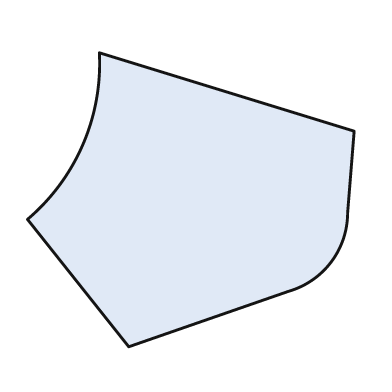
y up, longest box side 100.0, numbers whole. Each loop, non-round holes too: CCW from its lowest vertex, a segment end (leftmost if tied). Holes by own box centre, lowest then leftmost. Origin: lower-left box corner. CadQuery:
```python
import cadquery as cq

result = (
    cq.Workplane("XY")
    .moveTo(31.0, 0.0)
    .lineTo(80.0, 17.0)
    .threePointArc((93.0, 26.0), (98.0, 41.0))
    .lineTo(100.0, 66.0)
    .lineTo(22.0, 90.0)
    .threePointArc((17.0, 62.0), (0.0, 39.0))
    .close()
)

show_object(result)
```